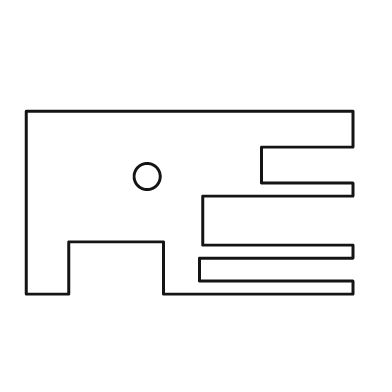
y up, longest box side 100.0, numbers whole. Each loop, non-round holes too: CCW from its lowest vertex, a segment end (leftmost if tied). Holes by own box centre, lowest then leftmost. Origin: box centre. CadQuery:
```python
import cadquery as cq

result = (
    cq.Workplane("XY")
    .moveTo(-50.0, -28.0)
    .lineTo(-37.0, -28.0)
    .lineTo(-37.0, -12.0)
    .lineTo(-8.0, -12.0)
    .lineTo(-8.0, -28.0)
    .lineTo(50.0, -28.0)
    .lineTo(50.0, -24.0)
    .lineTo(3.0, -24.0)
    .lineTo(3.0, -17.0)
    .lineTo(50.0, -17.0)
    .lineTo(50.0, -13.0)
    .lineTo(4.0, -13.0)
    .lineTo(4.0, 2.0)
    .lineTo(50.0, 2.0)
    .lineTo(50.0, 6.0)
    .lineTo(22.0, 6.0)
    .lineTo(22.0, 17.0)
    .lineTo(50.0, 17.0)
    .lineTo(50.0, 28.0)
    .lineTo(-50.0, 28.0)
    .close()
    .moveTo(-13.0, 8.0)
    .circle(4.0)
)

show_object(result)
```